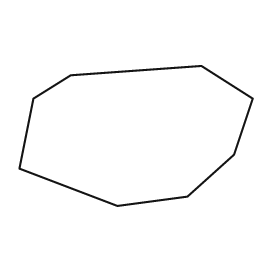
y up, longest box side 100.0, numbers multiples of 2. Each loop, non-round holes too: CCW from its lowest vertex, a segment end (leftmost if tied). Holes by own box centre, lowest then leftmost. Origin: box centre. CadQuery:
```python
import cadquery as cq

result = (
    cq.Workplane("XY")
    .moveTo(-8.0, -30.0)
    .lineTo(22.0, -26.0)
    .lineTo(42.0, -8.0)
    .lineTo(50.0, 16.0)
    .lineTo(28.0, 30.0)
    .lineTo(-28.0, 26.0)
    .lineTo(-44.0, 16.0)
    .lineTo(-50.0, -14.0)
    .close()
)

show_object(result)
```